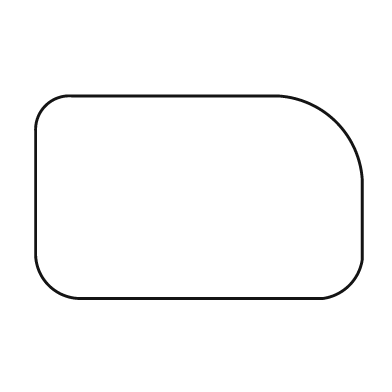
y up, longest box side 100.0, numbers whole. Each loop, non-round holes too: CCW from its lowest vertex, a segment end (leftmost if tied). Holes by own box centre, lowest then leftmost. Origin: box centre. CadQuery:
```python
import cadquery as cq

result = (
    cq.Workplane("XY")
    .moveTo(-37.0, -31.0)
    .lineTo(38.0, -31.0)
    .threePointArc((46.0, -27.0), (50.0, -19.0))
    .lineTo(50.0, 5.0)
    .threePointArc((42.0, 23.0), (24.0, 31.0))
    .lineTo(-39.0, 31.0)
    .threePointArc((-47.0, 28.0), (-50.0, 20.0))
    .lineTo(-50.0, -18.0)
    .threePointArc((-46.0, -27.0), (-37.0, -31.0))
    .close()
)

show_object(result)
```